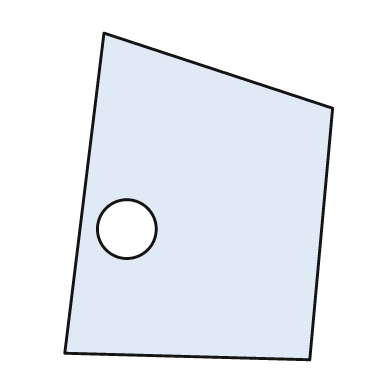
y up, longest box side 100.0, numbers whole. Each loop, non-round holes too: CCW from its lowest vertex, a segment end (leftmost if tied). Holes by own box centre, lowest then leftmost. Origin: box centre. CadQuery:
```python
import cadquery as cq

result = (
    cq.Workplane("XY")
    .moveTo(34.0, -50.0)
    .lineTo(41.0, 27.0)
    .lineTo(-29.0, 50.0)
    .lineTo(-41.0, -48.0)
    .close()
    .moveTo(-22.0, -10.0)
    .circle(9.0)
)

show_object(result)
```